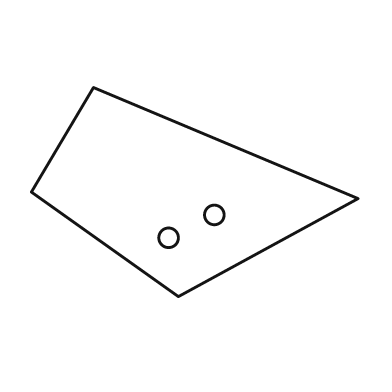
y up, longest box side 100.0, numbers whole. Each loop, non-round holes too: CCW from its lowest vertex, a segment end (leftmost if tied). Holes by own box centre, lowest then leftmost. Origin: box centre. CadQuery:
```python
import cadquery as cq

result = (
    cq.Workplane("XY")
    .moveTo(-5.0, -32.0)
    .lineTo(50.0, -2.0)
    .lineTo(-31.0, 32.0)
    .lineTo(-50.0, 0.0)
    .close()
    .moveTo(-8.0, -14.0)
    .circle(3.0)
    .moveTo(6.0, -7.0)
    .circle(3.0)
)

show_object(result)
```